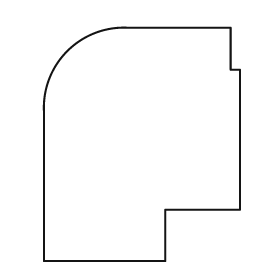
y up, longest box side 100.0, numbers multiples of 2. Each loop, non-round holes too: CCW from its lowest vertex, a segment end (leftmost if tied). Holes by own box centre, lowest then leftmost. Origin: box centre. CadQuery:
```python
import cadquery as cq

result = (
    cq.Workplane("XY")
    .moveTo(-42.0, -50.0)
    .lineTo(10.0, -50.0)
    .lineTo(10.0, -28.0)
    .lineTo(42.0, -28.0)
    .lineTo(42.0, 32.0)
    .lineTo(38.0, 32.0)
    .lineTo(38.0, 50.0)
    .lineTo(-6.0, 50.0)
    .threePointArc((-32.0, 40.0), (-42.0, 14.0))
    .close()
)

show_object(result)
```